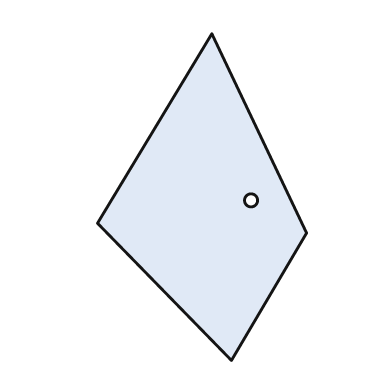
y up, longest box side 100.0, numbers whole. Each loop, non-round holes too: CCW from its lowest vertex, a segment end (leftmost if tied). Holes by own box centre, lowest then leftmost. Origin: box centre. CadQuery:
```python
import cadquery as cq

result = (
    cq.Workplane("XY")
    .moveTo(9.0, -50.0)
    .lineTo(32.0, -11.0)
    .lineTo(3.0, 50.0)
    .lineTo(-32.0, -8.0)
    .close()
    .moveTo(15.0, -1.0)
    .circle(2.0)
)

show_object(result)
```